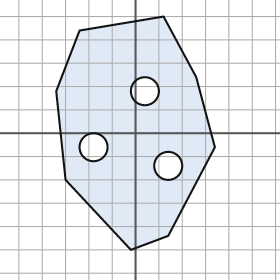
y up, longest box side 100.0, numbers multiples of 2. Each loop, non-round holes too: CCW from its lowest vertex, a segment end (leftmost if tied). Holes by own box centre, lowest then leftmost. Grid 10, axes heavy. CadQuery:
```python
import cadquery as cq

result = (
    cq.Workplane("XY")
    .moveTo(-2.0, -50.0)
    .lineTo(14.0, -44.0)
    .lineTo(34.0, -6.0)
    .lineTo(26.0, 24.0)
    .lineTo(12.0, 50.0)
    .lineTo(-24.0, 44.0)
    .lineTo(-34.0, 18.0)
    .lineTo(-30.0, -20.0)
    .close()
    .moveTo(14.0, -14.0)
    .circle(6.0)
    .moveTo(-18.0, -6.0)
    .circle(6.0)
    .moveTo(4.0, 18.0)
    .circle(6.0)
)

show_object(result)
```